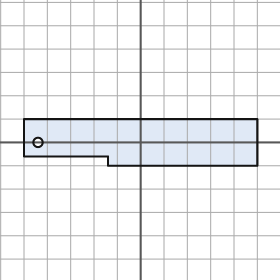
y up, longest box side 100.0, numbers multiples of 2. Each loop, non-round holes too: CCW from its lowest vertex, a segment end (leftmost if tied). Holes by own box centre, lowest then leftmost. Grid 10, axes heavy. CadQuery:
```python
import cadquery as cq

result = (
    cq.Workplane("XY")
    .moveTo(-14.0, -10.0)
    .lineTo(50.0, -10.0)
    .lineTo(50.0, 10.0)
    .lineTo(-50.0, 10.0)
    .lineTo(-50.0, -6.0)
    .lineTo(-14.0, -6.0)
    .close()
    .moveTo(-44.0, 0.0)
    .circle(2.0)
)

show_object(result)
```